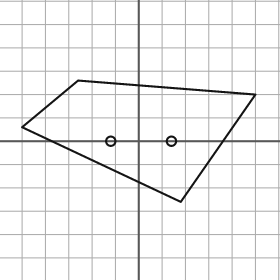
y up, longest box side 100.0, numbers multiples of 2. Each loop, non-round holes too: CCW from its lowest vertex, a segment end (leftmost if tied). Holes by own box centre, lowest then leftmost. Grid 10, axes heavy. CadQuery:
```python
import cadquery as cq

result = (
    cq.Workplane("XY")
    .moveTo(18.0, -26.0)
    .lineTo(50.0, 20.0)
    .lineTo(-26.0, 26.0)
    .lineTo(-50.0, 6.0)
    .close()
    .moveTo(-12.0, 0.0)
    .circle(2.0)
    .moveTo(14.0, 0.0)
    .circle(2.0)
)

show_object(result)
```